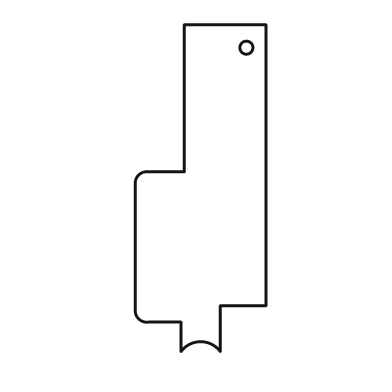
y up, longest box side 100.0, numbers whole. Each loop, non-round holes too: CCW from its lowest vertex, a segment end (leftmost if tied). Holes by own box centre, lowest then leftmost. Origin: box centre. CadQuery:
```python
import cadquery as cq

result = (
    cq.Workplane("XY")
    .moveTo(-6.0, -50.0)
    .threePointArc((0.0, -47.0), (6.0, -50.0))
    .lineTo(6.0, -36.0)
    .lineTo(20.0, -36.0)
    .lineTo(20.0, 50.0)
    .lineTo(-5.0, 50.0)
    .lineTo(-5.0, 5.0)
    .lineTo(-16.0, 5.0)
    .threePointArc((-19.0, 4.0), (-20.0, 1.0))
    .lineTo(-20.0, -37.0)
    .threePointArc((-19.0, -40.0), (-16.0, -41.0))
    .lineTo(-6.0, -41.0)
    .close()
    .moveTo(14.0, 43.0)
    .circle(2.0)
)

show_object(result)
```